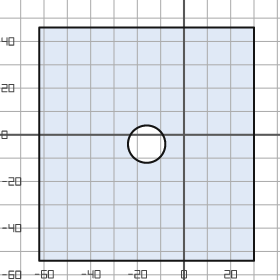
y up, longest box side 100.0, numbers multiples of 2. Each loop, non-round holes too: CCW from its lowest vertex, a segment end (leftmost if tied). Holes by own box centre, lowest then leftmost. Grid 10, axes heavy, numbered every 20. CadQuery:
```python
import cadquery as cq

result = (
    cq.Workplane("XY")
    .moveTo(-62.0, -54.0)
    .lineTo(30.0, -54.0)
    .lineTo(30.0, 46.0)
    .lineTo(-62.0, 46.0)
    .close()
    .moveTo(-16.0, -4.0)
    .circle(8.0)
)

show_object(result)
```